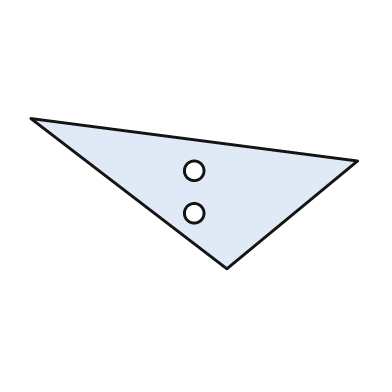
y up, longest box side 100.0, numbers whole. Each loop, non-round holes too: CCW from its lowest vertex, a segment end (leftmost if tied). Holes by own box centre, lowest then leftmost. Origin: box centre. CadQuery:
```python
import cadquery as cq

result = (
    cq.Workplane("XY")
    .moveTo(10.0, -23.0)
    .lineTo(50.0, 10.0)
    .lineTo(-50.0, 23.0)
    .close()
    .moveTo(0.0, -6.0)
    .circle(3.0)
    .moveTo(0.0, 7.0)
    .circle(3.0)
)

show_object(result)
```